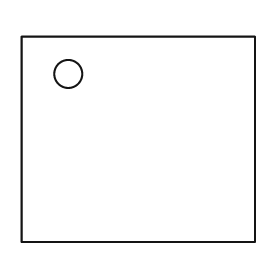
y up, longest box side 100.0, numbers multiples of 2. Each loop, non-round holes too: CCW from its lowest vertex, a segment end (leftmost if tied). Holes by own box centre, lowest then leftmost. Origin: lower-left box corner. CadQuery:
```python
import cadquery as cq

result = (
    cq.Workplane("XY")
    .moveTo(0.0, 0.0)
    .lineTo(100.0, 0.0)
    .lineTo(100.0, 88.0)
    .lineTo(0.0, 88.0)
    .close()
    .moveTo(20.0, 72.0)
    .circle(6.0)
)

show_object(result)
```